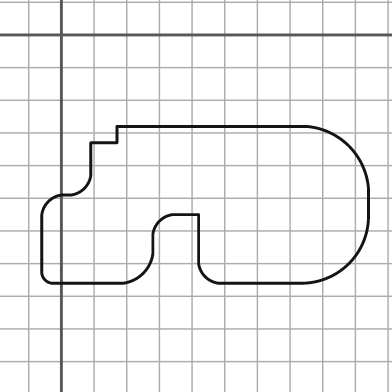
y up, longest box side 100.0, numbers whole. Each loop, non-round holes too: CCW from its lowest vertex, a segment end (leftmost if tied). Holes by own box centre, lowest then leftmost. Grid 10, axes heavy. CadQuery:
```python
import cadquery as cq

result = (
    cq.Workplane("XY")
    .moveTo(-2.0, -76.0)
    .lineTo(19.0, -76.0)
    .threePointArc((25.0, -73.0), (28.0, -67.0))
    .lineTo(28.0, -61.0)
    .threePointArc((30.0, -57.0), (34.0, -55.0))
    .lineTo(42.0, -55.0)
    .lineTo(42.0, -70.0)
    .threePointArc((44.0, -74.0), (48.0, -76.0))
    .lineTo(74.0, -76.0)
    .threePointArc((88.0, -70.0), (94.0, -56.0))
    .lineTo(94.0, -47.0)
    .threePointArc((88.0, -34.0), (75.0, -28.0))
    .lineTo(17.0, -28.0)
    .lineTo(17.0, -33.0)
    .lineTo(9.0, -33.0)
    .lineTo(9.0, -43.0)
    .threePointArc((7.0, -47.0), (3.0, -49.0))
    .lineTo(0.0, -49.0)
    .threePointArc((-4.0, -51.0), (-6.0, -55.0))
    .lineTo(-6.0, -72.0)
    .threePointArc((-5.0, -75.0), (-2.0, -76.0))
    .close()
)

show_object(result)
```